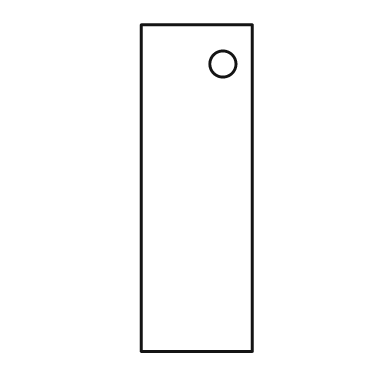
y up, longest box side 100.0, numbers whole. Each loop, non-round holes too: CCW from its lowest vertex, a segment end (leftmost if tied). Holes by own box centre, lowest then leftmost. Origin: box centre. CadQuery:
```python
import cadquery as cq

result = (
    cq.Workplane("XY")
    .moveTo(-17.0, -50.0)
    .lineTo(17.0, -50.0)
    .lineTo(17.0, 50.0)
    .lineTo(-17.0, 50.0)
    .close()
    .moveTo(8.0, 38.0)
    .circle(4.0)
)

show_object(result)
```